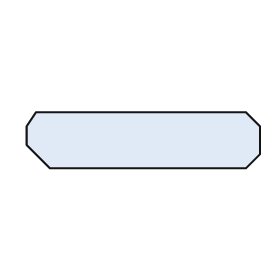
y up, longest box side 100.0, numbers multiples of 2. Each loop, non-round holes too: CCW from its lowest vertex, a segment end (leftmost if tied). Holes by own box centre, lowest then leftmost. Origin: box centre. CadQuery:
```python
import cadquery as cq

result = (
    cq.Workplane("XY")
    .moveTo(-40.0, -12.0)
    .lineTo(44.0, -12.0)
    .lineTo(50.0, -6.0)
    .lineTo(50.0, 6.0)
    .lineTo(44.0, 12.0)
    .lineTo(-46.0, 12.0)
    .lineTo(-50.0, 6.0)
    .lineTo(-50.0, -2.0)
    .close()
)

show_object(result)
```